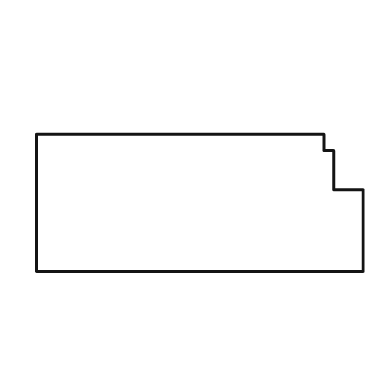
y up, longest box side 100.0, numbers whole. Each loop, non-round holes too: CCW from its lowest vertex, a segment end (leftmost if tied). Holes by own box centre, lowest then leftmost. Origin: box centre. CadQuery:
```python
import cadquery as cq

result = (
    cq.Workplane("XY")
    .moveTo(-50.0, -21.0)
    .lineTo(50.0, -21.0)
    .lineTo(50.0, 4.0)
    .lineTo(41.0, 4.0)
    .lineTo(41.0, 16.0)
    .lineTo(38.0, 16.0)
    .lineTo(38.0, 21.0)
    .lineTo(-50.0, 21.0)
    .close()
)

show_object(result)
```